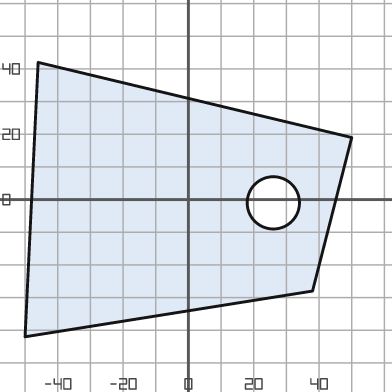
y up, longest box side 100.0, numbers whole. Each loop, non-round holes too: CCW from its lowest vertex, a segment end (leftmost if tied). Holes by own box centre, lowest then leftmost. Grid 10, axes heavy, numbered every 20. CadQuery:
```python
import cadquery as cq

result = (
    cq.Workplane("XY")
    .moveTo(-50.0, -42.0)
    .lineTo(38.0, -28.0)
    .lineTo(50.0, 19.0)
    .lineTo(-46.0, 42.0)
    .close()
    .moveTo(26.0, -1.0)
    .circle(8.0)
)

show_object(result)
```